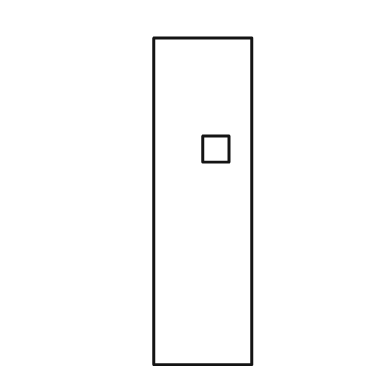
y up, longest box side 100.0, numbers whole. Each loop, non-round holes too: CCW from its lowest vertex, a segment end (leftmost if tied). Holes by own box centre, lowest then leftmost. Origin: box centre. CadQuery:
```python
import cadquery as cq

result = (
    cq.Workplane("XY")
    .moveTo(-15.0, -50.0)
    .lineTo(15.0, -50.0)
    .lineTo(15.0, 50.0)
    .lineTo(-15.0, 50.0)
    .close()
    .moveTo(0.0, 12.0)
    .lineTo(8.0, 12.0)
    .lineTo(8.0, 20.0)
    .lineTo(0.0, 20.0)
    .close()
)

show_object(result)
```